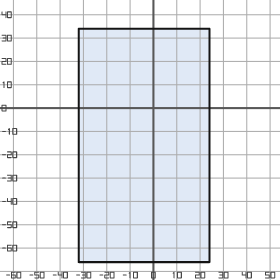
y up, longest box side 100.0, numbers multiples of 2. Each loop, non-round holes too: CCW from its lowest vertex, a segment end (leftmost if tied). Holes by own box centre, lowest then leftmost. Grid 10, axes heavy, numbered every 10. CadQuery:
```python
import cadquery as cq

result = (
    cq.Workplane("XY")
    .moveTo(-32.0, -66.0)
    .lineTo(24.0, -66.0)
    .lineTo(24.0, 34.0)
    .lineTo(-32.0, 34.0)
    .close()
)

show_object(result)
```